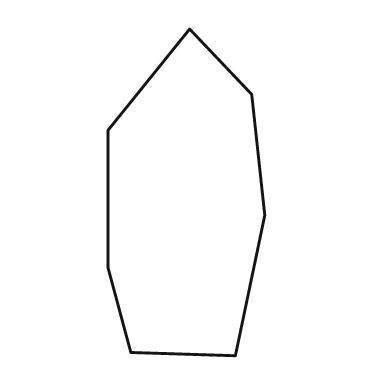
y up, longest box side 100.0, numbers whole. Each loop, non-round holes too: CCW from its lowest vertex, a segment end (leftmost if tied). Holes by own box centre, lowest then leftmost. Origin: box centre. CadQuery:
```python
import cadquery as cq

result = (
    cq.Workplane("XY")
    .moveTo(15.0, -50.0)
    .lineTo(24.0, -7.0)
    .lineTo(20.0, 30.0)
    .lineTo(1.0, 50.0)
    .lineTo(-24.0, 19.0)
    .lineTo(-24.0, -23.0)
    .lineTo(-17.0, -49.0)
    .close()
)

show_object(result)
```